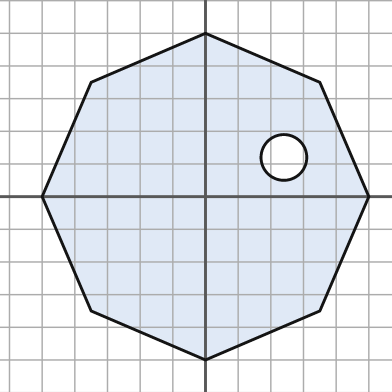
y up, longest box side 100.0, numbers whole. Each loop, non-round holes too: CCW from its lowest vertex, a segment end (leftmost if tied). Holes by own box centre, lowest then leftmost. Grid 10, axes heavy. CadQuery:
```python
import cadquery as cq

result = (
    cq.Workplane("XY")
    .moveTo(0.0, -50.0)
    .lineTo(35.0, -35.0)
    .lineTo(50.0, 0.0)
    .lineTo(35.0, 35.0)
    .lineTo(0.0, 50.0)
    .lineTo(-35.0, 35.0)
    .lineTo(-50.0, 0.0)
    .lineTo(-35.0, -35.0)
    .close()
    .moveTo(24.0, 12.0)
    .circle(7.0)
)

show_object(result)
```